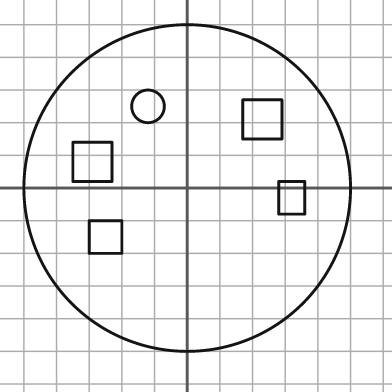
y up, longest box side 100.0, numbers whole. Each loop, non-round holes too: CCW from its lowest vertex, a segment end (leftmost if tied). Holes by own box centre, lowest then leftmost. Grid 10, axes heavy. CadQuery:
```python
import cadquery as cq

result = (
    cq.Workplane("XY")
    .moveTo(0.0, 0.0)
    .circle(50.0)
    .moveTo(-30.0, -20.0)
    .lineTo(-20.0, -20.0)
    .lineTo(-20.0, -10.0)
    .lineTo(-30.0, -10.0)
    .close()
    .moveTo(28.0, -8.0)
    .lineTo(36.0, -8.0)
    .lineTo(36.0, 2.0)
    .lineTo(28.0, 2.0)
    .close()
    .moveTo(-35.0, 2.0)
    .lineTo(-23.0, 2.0)
    .lineTo(-23.0, 14.0)
    .lineTo(-35.0, 14.0)
    .close()
    .moveTo(17.0, 15.0)
    .lineTo(29.0, 15.0)
    .lineTo(29.0, 27.0)
    .lineTo(17.0, 27.0)
    .close()
    .moveTo(-12.0, 25.0)
    .circle(5.0)
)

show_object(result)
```